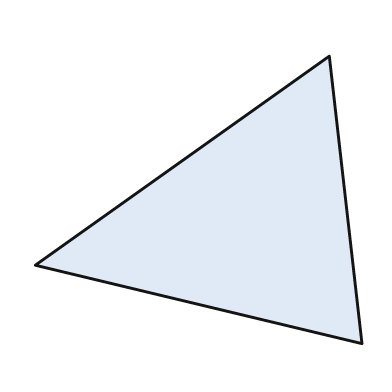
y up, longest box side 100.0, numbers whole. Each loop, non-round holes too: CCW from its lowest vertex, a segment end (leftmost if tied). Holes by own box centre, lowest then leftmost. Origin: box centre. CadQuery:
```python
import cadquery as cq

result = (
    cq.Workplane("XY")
    .moveTo(50.0, -44.0)
    .lineTo(40.0, 44.0)
    .lineTo(-50.0, -20.0)
    .close()
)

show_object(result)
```